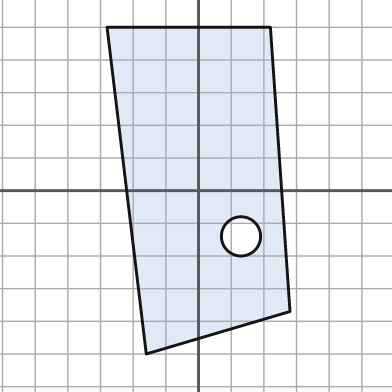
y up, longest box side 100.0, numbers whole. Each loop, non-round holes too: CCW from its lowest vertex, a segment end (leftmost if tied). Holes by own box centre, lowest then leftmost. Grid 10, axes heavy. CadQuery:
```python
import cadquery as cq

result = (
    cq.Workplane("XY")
    .moveTo(-16.0, -50.0)
    .lineTo(28.0, -37.0)
    .lineTo(22.0, 50.0)
    .lineTo(-28.0, 50.0)
    .close()
    .moveTo(13.0, -14.0)
    .circle(6.0)
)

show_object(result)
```